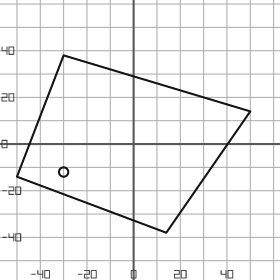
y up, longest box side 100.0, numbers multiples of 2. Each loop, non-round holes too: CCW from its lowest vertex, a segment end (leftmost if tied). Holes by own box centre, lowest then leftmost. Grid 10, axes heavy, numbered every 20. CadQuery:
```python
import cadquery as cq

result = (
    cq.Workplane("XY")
    .moveTo(14.0, -38.0)
    .lineTo(50.0, 14.0)
    .lineTo(-30.0, 38.0)
    .lineTo(-50.0, -14.0)
    .close()
    .moveTo(-30.0, -12.0)
    .circle(2.0)
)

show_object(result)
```